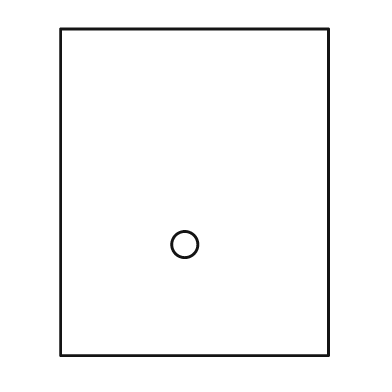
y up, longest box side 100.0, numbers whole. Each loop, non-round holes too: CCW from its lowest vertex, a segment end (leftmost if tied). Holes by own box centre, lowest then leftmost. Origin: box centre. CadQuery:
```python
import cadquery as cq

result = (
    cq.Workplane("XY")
    .moveTo(-41.0, -50.0)
    .lineTo(41.0, -50.0)
    .lineTo(41.0, 50.0)
    .lineTo(-41.0, 50.0)
    .close()
    .moveTo(-3.0, -16.0)
    .circle(4.0)
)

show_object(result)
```